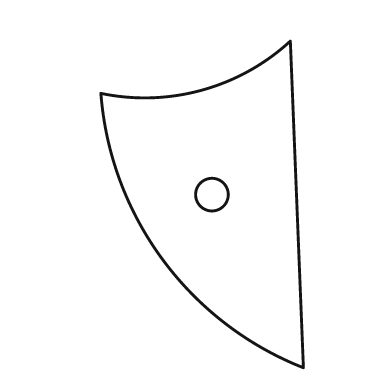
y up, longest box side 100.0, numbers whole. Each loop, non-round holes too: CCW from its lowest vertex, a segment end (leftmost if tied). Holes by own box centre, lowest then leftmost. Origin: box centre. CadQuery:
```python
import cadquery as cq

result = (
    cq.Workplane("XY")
    .moveTo(31.0, -50.0)
    .lineTo(27.0, 50.0)
    .threePointArc((0.0, 35.0), (-31.0, 34.0))
    .threePointArc((-12.0, -17.0), (31.0, -50.0))
    .close()
    .moveTo(3.0, 3.0)
    .circle(5.0)
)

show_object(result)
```